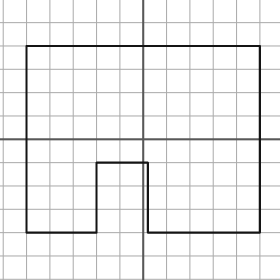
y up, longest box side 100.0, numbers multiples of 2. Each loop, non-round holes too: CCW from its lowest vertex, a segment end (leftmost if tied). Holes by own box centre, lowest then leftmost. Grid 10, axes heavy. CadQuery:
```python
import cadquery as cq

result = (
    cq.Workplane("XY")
    .moveTo(-50.0, -40.0)
    .lineTo(-20.0, -40.0)
    .lineTo(-20.0, -10.0)
    .lineTo(2.0, -10.0)
    .lineTo(2.0, -40.0)
    .lineTo(50.0, -40.0)
    .lineTo(50.0, 40.0)
    .lineTo(-50.0, 40.0)
    .close()
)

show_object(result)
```